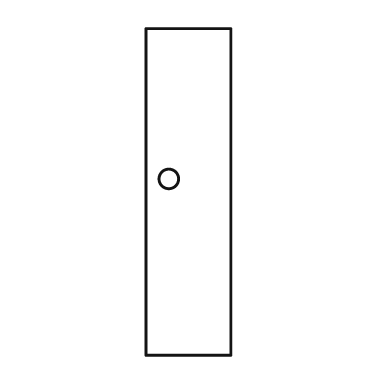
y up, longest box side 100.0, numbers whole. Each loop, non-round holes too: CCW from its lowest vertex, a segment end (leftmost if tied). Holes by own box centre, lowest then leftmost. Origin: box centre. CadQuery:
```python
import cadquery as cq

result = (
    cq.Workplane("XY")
    .moveTo(-13.0, -50.0)
    .lineTo(13.0, -50.0)
    .lineTo(13.0, 50.0)
    .lineTo(-13.0, 50.0)
    .close()
    .moveTo(-6.0, 4.0)
    .circle(3.0)
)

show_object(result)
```